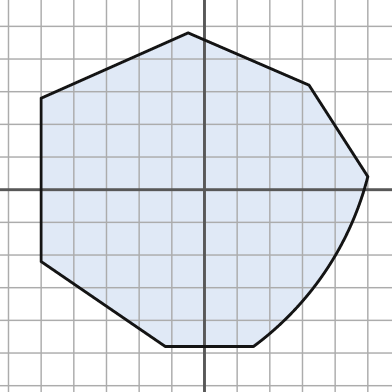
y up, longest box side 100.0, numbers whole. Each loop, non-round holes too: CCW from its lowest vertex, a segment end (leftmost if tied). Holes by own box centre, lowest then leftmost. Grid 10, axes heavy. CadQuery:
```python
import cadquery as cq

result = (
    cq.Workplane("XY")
    .moveTo(-12.0, -48.0)
    .lineTo(15.0, -48.0)
    .threePointArc((37.0, -25.0), (50.0, 4.0))
    .lineTo(32.0, 32.0)
    .lineTo(-5.0, 48.0)
    .lineTo(-50.0, 28.0)
    .lineTo(-50.0, -22.0)
    .close()
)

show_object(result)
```